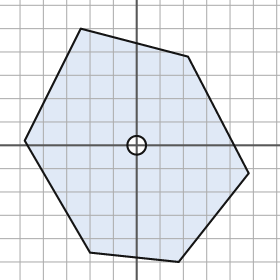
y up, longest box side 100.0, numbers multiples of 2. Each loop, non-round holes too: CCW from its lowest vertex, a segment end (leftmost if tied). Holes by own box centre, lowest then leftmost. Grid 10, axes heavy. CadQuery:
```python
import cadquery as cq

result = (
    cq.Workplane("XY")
    .moveTo(18.0, -50.0)
    .lineTo(48.0, -12.0)
    .lineTo(22.0, 38.0)
    .lineTo(-24.0, 50.0)
    .lineTo(-48.0, 2.0)
    .lineTo(-20.0, -46.0)
    .close()
    .moveTo(0.0, 0.0)
    .circle(4.0)
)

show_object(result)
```